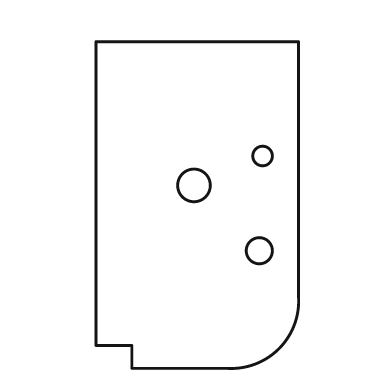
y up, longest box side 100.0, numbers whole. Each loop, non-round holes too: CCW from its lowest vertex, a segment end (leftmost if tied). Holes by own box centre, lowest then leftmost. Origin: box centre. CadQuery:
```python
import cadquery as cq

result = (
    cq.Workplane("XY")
    .moveTo(-20.0, -50.0)
    .lineTo(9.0, -50.0)
    .threePointArc((25.0, -44.0), (31.0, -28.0))
    .lineTo(31.0, 50.0)
    .lineTo(-31.0, 50.0)
    .lineTo(-31.0, -43.0)
    .lineTo(-20.0, -43.0)
    .close()
    .moveTo(19.0, -14.0)
    .circle(4.0)
    .moveTo(-1.0, 6.0)
    .circle(5.0)
    .moveTo(20.0, 15.0)
    .circle(3.0)
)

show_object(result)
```